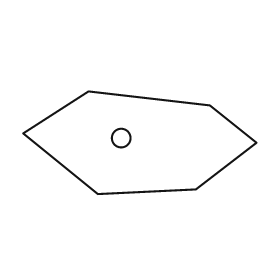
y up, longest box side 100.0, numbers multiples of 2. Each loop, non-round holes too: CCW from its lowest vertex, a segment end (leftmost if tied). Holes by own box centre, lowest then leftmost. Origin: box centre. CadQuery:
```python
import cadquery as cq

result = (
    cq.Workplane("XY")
    .moveTo(-18.0, -22.0)
    .lineTo(24.0, -20.0)
    .lineTo(50.0, 0.0)
    .lineTo(30.0, 16.0)
    .lineTo(-22.0, 22.0)
    .lineTo(-50.0, 4.0)
    .close()
    .moveTo(-8.0, 2.0)
    .circle(4.0)
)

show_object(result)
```